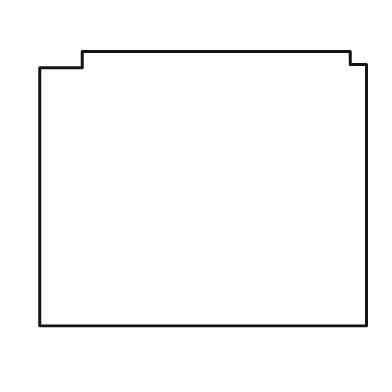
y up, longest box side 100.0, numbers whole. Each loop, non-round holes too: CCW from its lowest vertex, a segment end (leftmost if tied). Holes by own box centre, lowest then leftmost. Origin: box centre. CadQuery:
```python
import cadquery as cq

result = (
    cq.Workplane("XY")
    .moveTo(-50.0, -42.0)
    .lineTo(50.0, -42.0)
    .lineTo(50.0, 38.0)
    .lineTo(45.0, 38.0)
    .lineTo(45.0, 42.0)
    .lineTo(-37.0, 42.0)
    .lineTo(-37.0, 37.0)
    .lineTo(-50.0, 37.0)
    .close()
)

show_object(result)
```